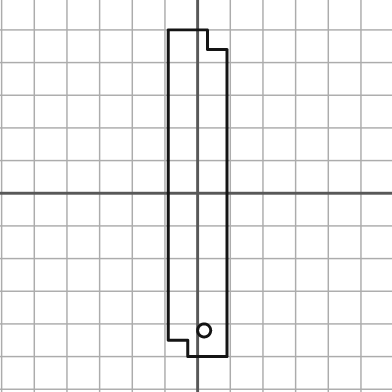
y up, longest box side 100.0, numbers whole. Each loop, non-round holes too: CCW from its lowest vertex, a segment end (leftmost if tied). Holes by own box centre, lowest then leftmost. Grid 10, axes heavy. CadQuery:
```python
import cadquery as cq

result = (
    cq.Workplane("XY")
    .moveTo(-3.0, -50.0)
    .lineTo(9.0, -50.0)
    .lineTo(9.0, 44.0)
    .lineTo(3.0, 44.0)
    .lineTo(3.0, 50.0)
    .lineTo(-9.0, 50.0)
    .lineTo(-9.0, -45.0)
    .lineTo(-3.0, -45.0)
    .close()
    .moveTo(2.0, -42.0)
    .circle(2.0)
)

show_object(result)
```